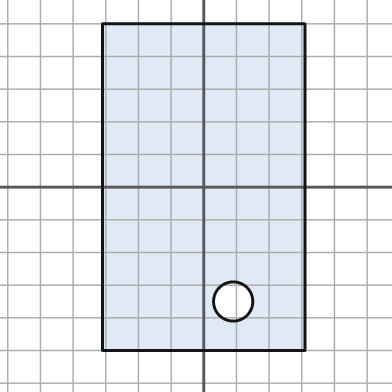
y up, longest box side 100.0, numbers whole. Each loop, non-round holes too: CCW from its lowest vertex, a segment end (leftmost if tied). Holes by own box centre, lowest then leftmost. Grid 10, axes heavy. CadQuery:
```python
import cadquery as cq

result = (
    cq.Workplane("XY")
    .moveTo(-31.0, -50.0)
    .lineTo(31.0, -50.0)
    .lineTo(31.0, 50.0)
    .lineTo(-31.0, 50.0)
    .close()
    .moveTo(9.0, -35.0)
    .circle(6.0)
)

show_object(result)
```